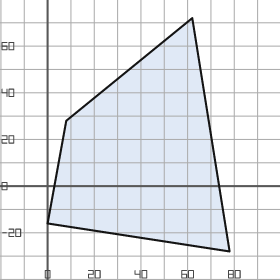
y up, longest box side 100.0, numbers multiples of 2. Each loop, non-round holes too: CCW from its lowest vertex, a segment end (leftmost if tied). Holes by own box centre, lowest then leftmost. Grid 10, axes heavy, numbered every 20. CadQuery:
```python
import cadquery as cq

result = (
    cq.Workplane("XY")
    .moveTo(78.0, -28.0)
    .lineTo(62.0, 72.0)
    .lineTo(8.0, 28.0)
    .lineTo(0.0, -16.0)
    .close()
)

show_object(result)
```